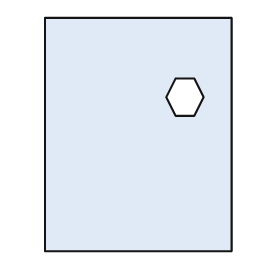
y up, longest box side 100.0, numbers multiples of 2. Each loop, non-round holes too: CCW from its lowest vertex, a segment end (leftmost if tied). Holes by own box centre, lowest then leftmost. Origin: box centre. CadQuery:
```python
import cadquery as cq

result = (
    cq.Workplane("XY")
    .moveTo(-40.0, -50.0)
    .lineTo(40.0, -50.0)
    .lineTo(40.0, 50.0)
    .lineTo(-40.0, 50.0)
    .close()
    .moveTo(16.0, 8.0)
    .lineTo(24.0, 8.0)
    .lineTo(28.0, 16.0)
    .lineTo(24.0, 24.0)
    .lineTo(16.0, 24.0)
    .lineTo(12.0, 16.0)
    .close()
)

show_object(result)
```